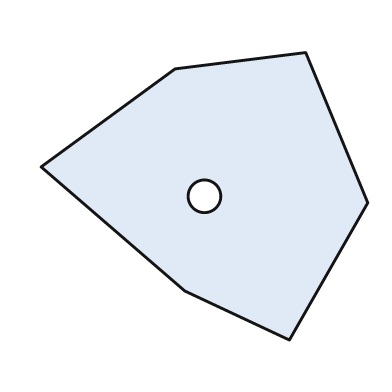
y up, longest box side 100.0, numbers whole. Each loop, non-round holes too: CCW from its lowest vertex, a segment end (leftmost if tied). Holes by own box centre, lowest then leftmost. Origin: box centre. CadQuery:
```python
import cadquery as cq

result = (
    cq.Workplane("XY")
    .moveTo(26.0, -44.0)
    .lineTo(50.0, -2.0)
    .lineTo(31.0, 44.0)
    .lineTo(-9.0, 39.0)
    .lineTo(-50.0, 9.0)
    .lineTo(-6.0, -29.0)
    .close()
    .moveTo(0.0, 0.0)
    .circle(5.0)
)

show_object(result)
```